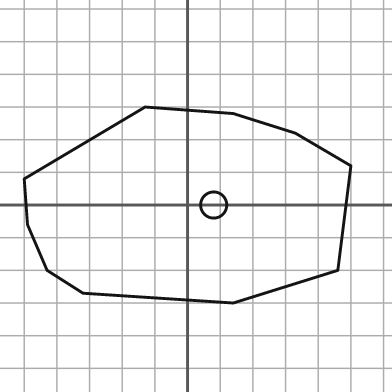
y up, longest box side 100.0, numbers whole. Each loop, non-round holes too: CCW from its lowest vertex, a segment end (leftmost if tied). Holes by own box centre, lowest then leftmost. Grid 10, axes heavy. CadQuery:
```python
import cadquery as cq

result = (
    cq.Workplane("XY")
    .moveTo(14.0, -30.0)
    .lineTo(46.0, -20.0)
    .lineTo(50.0, 12.0)
    .lineTo(33.0, 22.0)
    .lineTo(14.0, 28.0)
    .lineTo(-13.0, 30.0)
    .lineTo(-50.0, 8.0)
    .lineTo(-49.0, -6.0)
    .lineTo(-43.0, -20.0)
    .lineTo(-32.0, -27.0)
    .close()
    .moveTo(8.0, 0.0)
    .circle(4.0)
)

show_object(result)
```